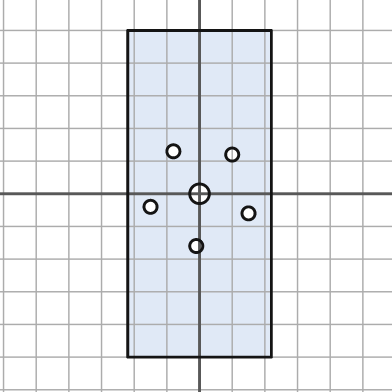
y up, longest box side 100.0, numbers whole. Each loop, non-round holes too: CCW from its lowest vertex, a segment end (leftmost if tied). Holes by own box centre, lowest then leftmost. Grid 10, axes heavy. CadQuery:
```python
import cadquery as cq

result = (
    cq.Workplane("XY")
    .moveTo(-22.0, -50.0)
    .lineTo(22.0, -50.0)
    .lineTo(22.0, 50.0)
    .lineTo(-22.0, 50.0)
    .close()
    .moveTo(-1.0, -16.0)
    .circle(2.0)
    .moveTo(15.0, -6.0)
    .circle(2.0)
    .moveTo(-15.0, -4.0)
    .circle(2.0)
    .moveTo(0.0, 0.0)
    .circle(3.0)
    .moveTo(10.0, 12.0)
    .circle(2.0)
    .moveTo(-8.0, 13.0)
    .circle(2.0)
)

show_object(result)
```